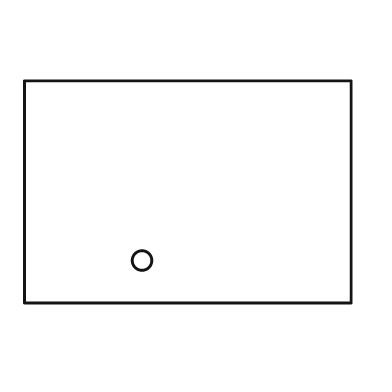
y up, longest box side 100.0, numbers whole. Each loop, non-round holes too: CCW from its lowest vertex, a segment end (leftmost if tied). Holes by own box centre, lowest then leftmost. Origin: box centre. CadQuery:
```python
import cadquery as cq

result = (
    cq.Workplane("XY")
    .moveTo(-50.0, -34.0)
    .lineTo(50.0, -34.0)
    .lineTo(50.0, 34.0)
    .lineTo(-50.0, 34.0)
    .close()
    .moveTo(-14.0, -21.0)
    .circle(3.0)
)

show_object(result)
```